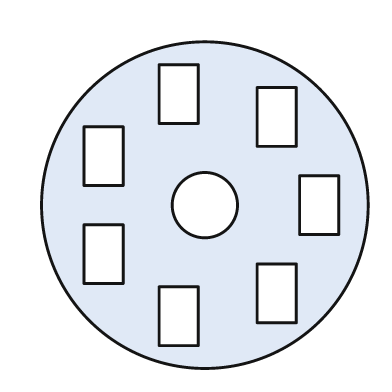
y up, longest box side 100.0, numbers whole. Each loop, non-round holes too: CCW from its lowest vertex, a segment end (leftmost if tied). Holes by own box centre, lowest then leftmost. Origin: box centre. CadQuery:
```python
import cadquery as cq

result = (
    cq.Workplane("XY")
    .moveTo(0.0, 0.0)
    .circle(50.0)
    .moveTo(-14.0, -43.0)
    .lineTo(-2.0, -43.0)
    .lineTo(-2.0, -25.0)
    .lineTo(-14.0, -25.0)
    .close()
    .moveTo(16.0, -36.0)
    .lineTo(28.0, -36.0)
    .lineTo(28.0, -18.0)
    .lineTo(16.0, -18.0)
    .close()
    .moveTo(-37.0, -24.0)
    .lineTo(-25.0, -24.0)
    .lineTo(-25.0, -6.0)
    .lineTo(-37.0, -6.0)
    .close()
    .moveTo(0.0, 0.0)
    .circle(10.0)
    .moveTo(29.0, -9.0)
    .lineTo(41.0, -9.0)
    .lineTo(41.0, 9.0)
    .lineTo(29.0, 9.0)
    .close()
    .moveTo(-37.0, 6.0)
    .lineTo(-25.0, 6.0)
    .lineTo(-25.0, 24.0)
    .lineTo(-37.0, 24.0)
    .close()
    .moveTo(16.0, 18.0)
    .lineTo(28.0, 18.0)
    .lineTo(28.0, 36.0)
    .lineTo(16.0, 36.0)
    .close()
    .moveTo(-14.0, 25.0)
    .lineTo(-2.0, 25.0)
    .lineTo(-2.0, 43.0)
    .lineTo(-14.0, 43.0)
    .close()
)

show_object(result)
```